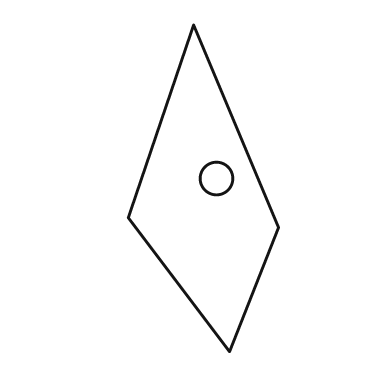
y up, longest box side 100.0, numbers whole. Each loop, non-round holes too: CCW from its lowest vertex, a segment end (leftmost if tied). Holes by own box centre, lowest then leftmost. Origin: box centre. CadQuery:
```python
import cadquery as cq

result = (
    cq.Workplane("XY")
    .moveTo(8.0, -50.0)
    .lineTo(23.0, -12.0)
    .lineTo(-3.0, 50.0)
    .lineTo(-23.0, -9.0)
    .close()
    .moveTo(4.0, 3.0)
    .circle(5.0)
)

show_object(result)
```